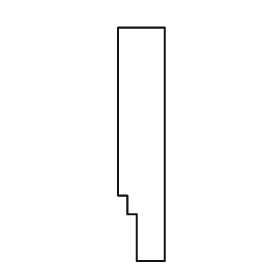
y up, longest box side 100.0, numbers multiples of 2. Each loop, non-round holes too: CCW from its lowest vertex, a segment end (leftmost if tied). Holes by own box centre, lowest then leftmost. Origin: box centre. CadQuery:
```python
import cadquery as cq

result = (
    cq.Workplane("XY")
    .moveTo(-2.0, -50.0)
    .lineTo(10.0, -50.0)
    .lineTo(10.0, 50.0)
    .lineTo(-10.0, 50.0)
    .lineTo(-10.0, -22.0)
    .lineTo(-6.0, -22.0)
    .lineTo(-6.0, -30.0)
    .lineTo(-2.0, -30.0)
    .close()
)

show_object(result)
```